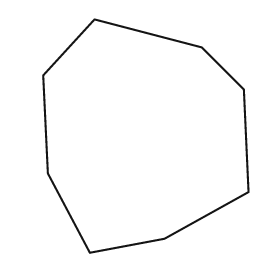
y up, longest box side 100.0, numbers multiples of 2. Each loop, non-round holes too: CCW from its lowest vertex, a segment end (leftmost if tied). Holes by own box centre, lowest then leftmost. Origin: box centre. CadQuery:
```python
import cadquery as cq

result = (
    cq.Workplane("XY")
    .moveTo(-24.0, -50.0)
    .lineTo(8.0, -44.0)
    .lineTo(44.0, -24.0)
    .lineTo(42.0, 20.0)
    .lineTo(24.0, 38.0)
    .lineTo(-22.0, 50.0)
    .lineTo(-44.0, 26.0)
    .lineTo(-42.0, -16.0)
    .close()
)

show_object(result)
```